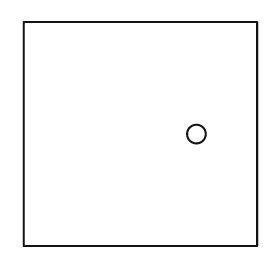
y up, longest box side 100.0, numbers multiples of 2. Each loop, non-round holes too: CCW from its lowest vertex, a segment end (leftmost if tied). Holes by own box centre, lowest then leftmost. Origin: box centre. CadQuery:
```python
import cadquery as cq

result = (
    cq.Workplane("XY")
    .moveTo(-50.0, -48.0)
    .lineTo(50.0, -48.0)
    .lineTo(50.0, 48.0)
    .lineTo(-50.0, 48.0)
    .close()
    .moveTo(24.0, 0.0)
    .circle(4.0)
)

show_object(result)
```